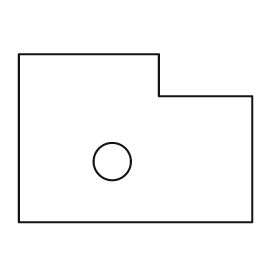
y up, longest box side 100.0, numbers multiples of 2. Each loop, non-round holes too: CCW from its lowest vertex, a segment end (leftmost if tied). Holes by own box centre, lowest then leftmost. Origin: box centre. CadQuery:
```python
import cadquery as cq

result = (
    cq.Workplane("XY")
    .moveTo(-50.0, -36.0)
    .lineTo(50.0, -36.0)
    .lineTo(50.0, 18.0)
    .lineTo(10.0, 18.0)
    .lineTo(10.0, 36.0)
    .lineTo(-50.0, 36.0)
    .close()
    .moveTo(-10.0, -10.0)
    .circle(8.0)
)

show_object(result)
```